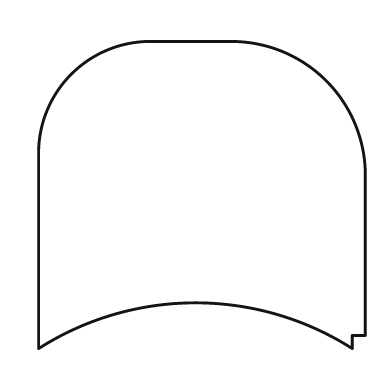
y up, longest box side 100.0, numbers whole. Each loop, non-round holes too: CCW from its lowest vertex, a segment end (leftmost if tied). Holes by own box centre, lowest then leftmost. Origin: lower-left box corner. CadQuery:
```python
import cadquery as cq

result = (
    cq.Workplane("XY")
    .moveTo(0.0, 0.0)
    .threePointArc((48.0, 14.0), (96.0, 0.0))
    .lineTo(96.0, 4.0)
    .lineTo(100.0, 4.0)
    .lineTo(100.0, 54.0)
    .threePointArc((88.0, 82.0), (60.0, 94.0))
    .lineTo(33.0, 94.0)
    .threePointArc((10.0, 84.0), (0.0, 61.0))
    .close()
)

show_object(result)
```